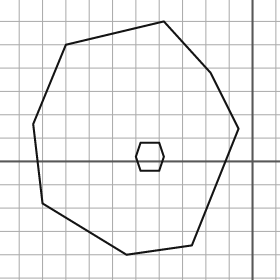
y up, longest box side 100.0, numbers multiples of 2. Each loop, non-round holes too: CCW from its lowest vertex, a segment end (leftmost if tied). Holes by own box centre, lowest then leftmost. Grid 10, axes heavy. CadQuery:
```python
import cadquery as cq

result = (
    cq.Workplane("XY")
    .moveTo(-54.0, -40.0)
    .lineTo(-26.0, -36.0)
    .lineTo(-6.0, 14.0)
    .lineTo(-18.0, 38.0)
    .lineTo(-38.0, 60.0)
    .lineTo(-80.0, 50.0)
    .lineTo(-94.0, 16.0)
    .lineTo(-90.0, -18.0)
    .close()
    .moveTo(-48.0, -4.0)
    .lineTo(-40.0, -4.0)
    .lineTo(-38.0, 2.0)
    .lineTo(-40.0, 8.0)
    .lineTo(-48.0, 8.0)
    .lineTo(-50.0, 2.0)
    .close()
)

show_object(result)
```